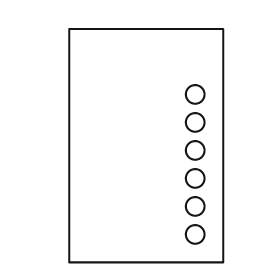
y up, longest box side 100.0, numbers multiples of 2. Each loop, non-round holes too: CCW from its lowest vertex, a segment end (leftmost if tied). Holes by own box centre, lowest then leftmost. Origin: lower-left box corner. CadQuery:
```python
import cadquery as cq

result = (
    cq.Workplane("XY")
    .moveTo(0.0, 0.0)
    .lineTo(66.0, 0.0)
    .lineTo(66.0, 100.0)
    .lineTo(0.0, 100.0)
    .close()
    .moveTo(54.0, 12.0)
    .circle(4.0)
    .moveTo(54.0, 24.0)
    .circle(4.0)
    .moveTo(54.0, 36.0)
    .circle(4.0)
    .moveTo(54.0, 48.0)
    .circle(4.0)
    .moveTo(54.0, 60.0)
    .circle(4.0)
    .moveTo(54.0, 72.0)
    .circle(4.0)
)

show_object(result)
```